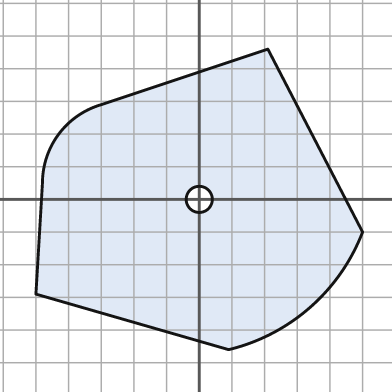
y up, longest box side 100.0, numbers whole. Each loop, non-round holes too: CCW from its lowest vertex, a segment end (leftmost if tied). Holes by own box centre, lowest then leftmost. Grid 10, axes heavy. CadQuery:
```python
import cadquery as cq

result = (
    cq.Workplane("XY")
    .moveTo(9.0, -46.0)
    .threePointArc((34.0, -33.0), (50.0, -10.0))
    .lineTo(21.0, 46.0)
    .lineTo(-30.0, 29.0)
    .threePointArc((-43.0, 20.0), (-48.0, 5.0))
    .lineTo(-50.0, -29.0)
    .close()
    .moveTo(0.0, 0.0)
    .circle(4.0)
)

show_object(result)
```